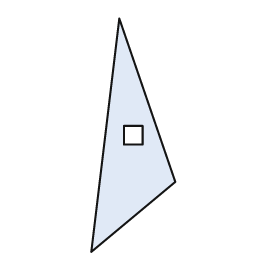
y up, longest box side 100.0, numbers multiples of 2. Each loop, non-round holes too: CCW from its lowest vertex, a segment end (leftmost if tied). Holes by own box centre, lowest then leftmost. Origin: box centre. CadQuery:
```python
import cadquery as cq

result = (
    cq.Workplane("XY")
    .moveTo(-18.0, -50.0)
    .lineTo(18.0, -20.0)
    .lineTo(-6.0, 50.0)
    .close()
    .moveTo(-4.0, -4.0)
    .lineTo(4.0, -4.0)
    .lineTo(4.0, 4.0)
    .lineTo(-4.0, 4.0)
    .close()
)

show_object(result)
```